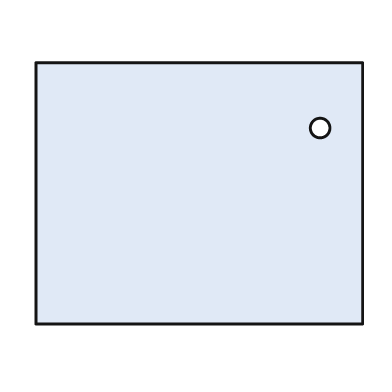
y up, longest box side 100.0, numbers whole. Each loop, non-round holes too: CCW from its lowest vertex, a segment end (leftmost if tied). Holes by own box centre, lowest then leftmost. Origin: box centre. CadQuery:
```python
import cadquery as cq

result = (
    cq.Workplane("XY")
    .moveTo(-50.0, -40.0)
    .lineTo(50.0, -40.0)
    .lineTo(50.0, 40.0)
    .lineTo(-50.0, 40.0)
    .close()
    .moveTo(37.0, 20.0)
    .circle(3.0)
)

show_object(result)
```